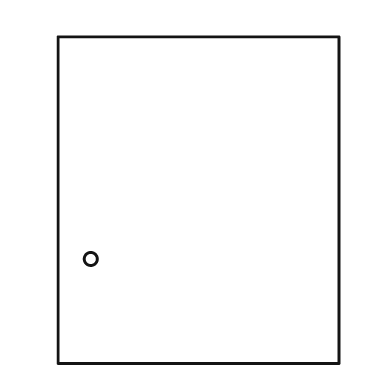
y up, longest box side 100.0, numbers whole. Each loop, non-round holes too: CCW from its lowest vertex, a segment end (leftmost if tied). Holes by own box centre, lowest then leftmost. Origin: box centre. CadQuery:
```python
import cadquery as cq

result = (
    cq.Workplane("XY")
    .moveTo(-43.0, -50.0)
    .lineTo(43.0, -50.0)
    .lineTo(43.0, 50.0)
    .lineTo(-43.0, 50.0)
    .close()
    .moveTo(-33.0, -18.0)
    .circle(2.0)
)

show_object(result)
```